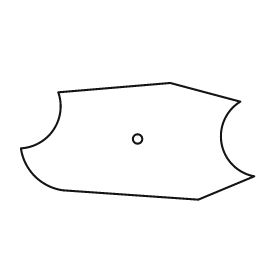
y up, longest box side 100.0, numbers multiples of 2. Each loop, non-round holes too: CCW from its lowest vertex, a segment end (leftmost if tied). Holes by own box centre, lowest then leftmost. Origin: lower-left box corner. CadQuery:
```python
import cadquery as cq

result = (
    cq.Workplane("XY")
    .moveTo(76.0, 0.0)
    .lineTo(100.0, 10.0)
    .threePointArc((86.0, 24.0), (94.0, 42.0))
    .lineTo(64.0, 50.0)
    .lineTo(16.0, 46.0)
    .threePointArc((14.0, 30.0), (0.0, 22.0))
    .threePointArc((6.0, 10.0), (18.0, 4.0))
    .close()
    .moveTo(50.0, 26.0)
    .circle(2.0)
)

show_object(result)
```